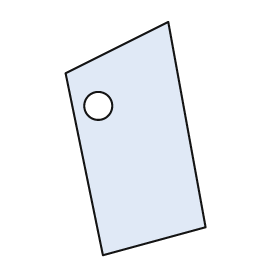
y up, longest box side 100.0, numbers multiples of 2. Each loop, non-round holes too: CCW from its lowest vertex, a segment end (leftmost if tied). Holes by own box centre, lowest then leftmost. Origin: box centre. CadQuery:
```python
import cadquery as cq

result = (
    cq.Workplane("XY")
    .moveTo(-14.0, -50.0)
    .lineTo(30.0, -38.0)
    .lineTo(14.0, 50.0)
    .lineTo(-30.0, 28.0)
    .close()
    .moveTo(-16.0, 14.0)
    .circle(6.0)
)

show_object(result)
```